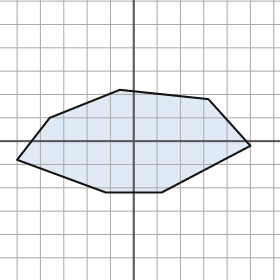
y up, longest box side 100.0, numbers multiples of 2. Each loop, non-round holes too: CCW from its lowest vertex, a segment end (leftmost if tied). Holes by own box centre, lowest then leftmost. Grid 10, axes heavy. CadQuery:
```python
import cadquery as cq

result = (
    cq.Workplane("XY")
    .moveTo(-12.0, -22.0)
    .lineTo(12.0, -22.0)
    .lineTo(50.0, -2.0)
    .lineTo(32.0, 18.0)
    .lineTo(-6.0, 22.0)
    .lineTo(-36.0, 10.0)
    .lineTo(-50.0, -8.0)
    .close()
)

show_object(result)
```